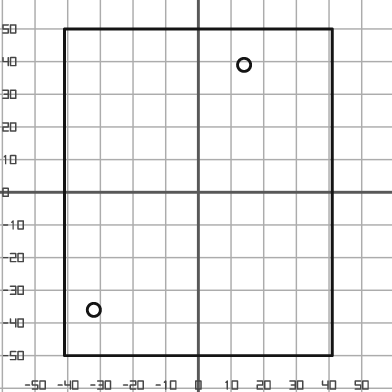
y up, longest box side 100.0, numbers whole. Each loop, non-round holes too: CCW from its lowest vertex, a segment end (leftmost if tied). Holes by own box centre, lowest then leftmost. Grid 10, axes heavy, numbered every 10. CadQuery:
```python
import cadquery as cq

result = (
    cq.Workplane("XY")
    .moveTo(-41.0, -50.0)
    .lineTo(41.0, -50.0)
    .lineTo(41.0, 50.0)
    .lineTo(-41.0, 50.0)
    .close()
    .moveTo(-32.0, -36.0)
    .circle(2.0)
    .moveTo(14.0, 39.0)
    .circle(2.0)
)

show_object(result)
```